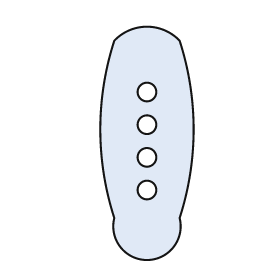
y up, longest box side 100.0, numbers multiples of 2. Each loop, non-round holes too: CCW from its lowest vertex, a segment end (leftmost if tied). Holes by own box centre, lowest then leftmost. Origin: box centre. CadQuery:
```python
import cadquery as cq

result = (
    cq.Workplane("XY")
    .moveTo(-14.0, -32.0)
    .threePointArc((0.0, -50.0), (14.0, -32.0))
    .threePointArc((20.0, 6.0), (14.0, 44.0))
    .threePointArc((0.0, 50.0), (-14.0, 44.0))
    .threePointArc((-20.0, 6.0), (-14.0, -32.0))
    .close()
    .moveTo(0.0, -20.0)
    .circle(4.0)
    .moveTo(0.0, -6.0)
    .circle(4.0)
    .moveTo(0.0, 8.0)
    .circle(4.0)
    .moveTo(0.0, 22.0)
    .circle(4.0)
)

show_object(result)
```